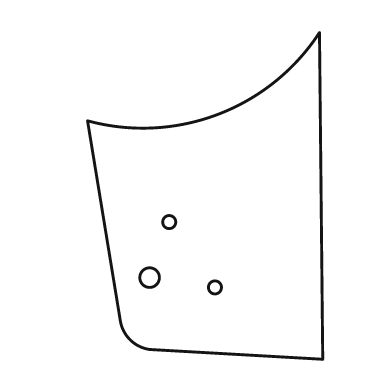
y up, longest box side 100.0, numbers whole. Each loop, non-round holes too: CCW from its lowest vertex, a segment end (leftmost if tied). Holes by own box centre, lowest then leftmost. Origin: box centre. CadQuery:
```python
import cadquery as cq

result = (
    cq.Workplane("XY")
    .moveTo(36.0, -50.0)
    .lineTo(35.0, 50.0)
    .threePointArc((4.0, 25.0), (-36.0, 23.0))
    .lineTo(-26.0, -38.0)
    .threePointArc((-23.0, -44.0), (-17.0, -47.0))
    .close()
    .moveTo(3.0, -28.0)
    .circle(2.0)
    .moveTo(-17.0, -25.0)
    .circle(3.0)
    .moveTo(-11.0, -8.0)
    .circle(2.0)
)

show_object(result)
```